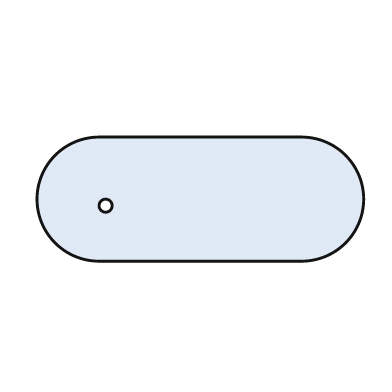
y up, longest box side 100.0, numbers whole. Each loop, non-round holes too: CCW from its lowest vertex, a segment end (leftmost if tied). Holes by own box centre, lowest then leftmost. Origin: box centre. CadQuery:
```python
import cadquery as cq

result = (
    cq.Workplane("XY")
    .moveTo(-31.0, -19.0)
    .lineTo(31.0, -19.0)
    .threePointArc((50.0, 0.0), (31.0, 19.0))
    .lineTo(-31.0, 19.0)
    .threePointArc((-50.0, 0.0), (-31.0, -19.0))
    .close()
    .moveTo(-29.0, -2.0)
    .circle(2.0)
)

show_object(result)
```